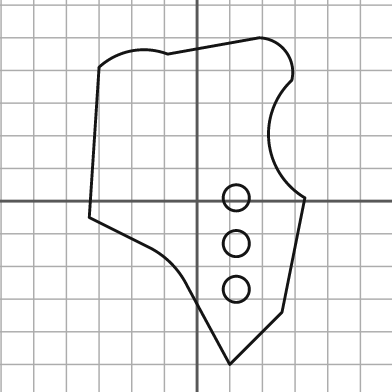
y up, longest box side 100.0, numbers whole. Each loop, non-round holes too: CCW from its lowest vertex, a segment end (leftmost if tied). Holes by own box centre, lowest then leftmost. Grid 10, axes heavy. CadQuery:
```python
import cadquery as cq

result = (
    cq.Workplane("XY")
    .moveTo(10.0, -50.0)
    .lineTo(26.0, -34.0)
    .lineTo(33.0, 1.0)
    .threePointArc((22.0, 18.0), (29.0, 37.0))
    .threePointArc((27.0, 46.0), (19.0, 50.0))
    .lineTo(-9.0, 45.0)
    .threePointArc((-20.0, 46.0), (-30.0, 41.0))
    .lineTo(-33.0, -5.0)
    .lineTo(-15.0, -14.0)
    .threePointArc((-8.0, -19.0), (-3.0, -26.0))
    .close()
    .moveTo(12.0, -27.0)
    .circle(4.0)
    .moveTo(12.0, -13.0)
    .circle(4.0)
    .moveTo(12.0, 1.0)
    .circle(4.0)
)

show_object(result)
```